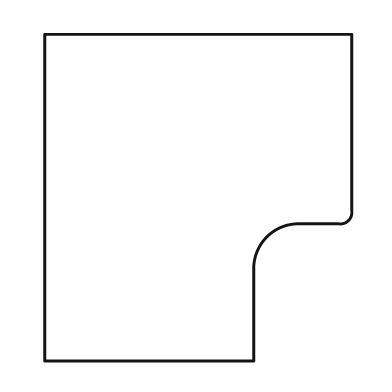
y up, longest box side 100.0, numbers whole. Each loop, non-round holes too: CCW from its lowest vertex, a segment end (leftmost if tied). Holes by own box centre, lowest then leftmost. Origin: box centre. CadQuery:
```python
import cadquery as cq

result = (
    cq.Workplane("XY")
    .moveTo(-47.0, -50.0)
    .lineTo(17.0, -50.0)
    .lineTo(17.0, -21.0)
    .threePointArc((21.0, -12.0), (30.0, -8.0))
    .lineTo(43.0, -8.0)
    .threePointArc((46.0, -7.0), (47.0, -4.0))
    .lineTo(47.0, 50.0)
    .lineTo(-47.0, 50.0)
    .close()
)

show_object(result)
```